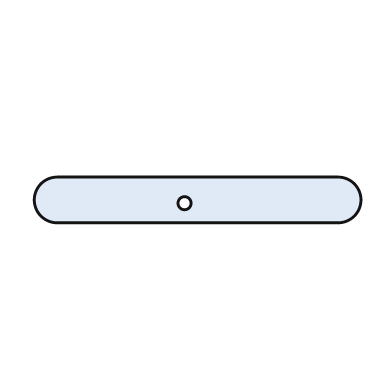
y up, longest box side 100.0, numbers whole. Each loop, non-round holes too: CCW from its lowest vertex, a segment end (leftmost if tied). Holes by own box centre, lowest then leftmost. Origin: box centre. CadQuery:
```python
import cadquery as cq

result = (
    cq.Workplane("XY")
    .moveTo(-43.0, -7.0)
    .lineTo(43.0, -7.0)
    .threePointArc((50.0, 0.0), (43.0, 7.0))
    .lineTo(-43.0, 7.0)
    .threePointArc((-50.0, 0.0), (-43.0, -7.0))
    .close()
    .moveTo(-4.0, -1.0)
    .circle(2.0)
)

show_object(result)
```